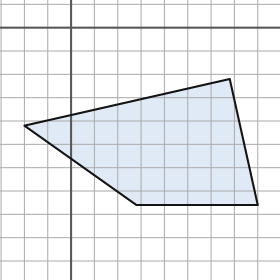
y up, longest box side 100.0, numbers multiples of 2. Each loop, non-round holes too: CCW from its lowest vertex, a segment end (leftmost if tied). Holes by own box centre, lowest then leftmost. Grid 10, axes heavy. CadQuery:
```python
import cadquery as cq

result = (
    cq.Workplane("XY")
    .moveTo(28.0, -76.0)
    .lineTo(80.0, -76.0)
    .lineTo(68.0, -22.0)
    .lineTo(-20.0, -42.0)
    .close()
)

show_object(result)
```